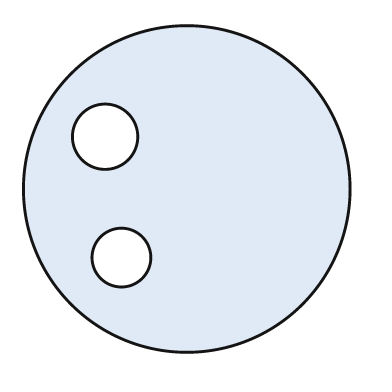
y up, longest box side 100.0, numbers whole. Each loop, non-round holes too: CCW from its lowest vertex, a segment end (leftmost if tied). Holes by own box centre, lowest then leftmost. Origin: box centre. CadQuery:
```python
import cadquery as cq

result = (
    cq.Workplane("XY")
    .moveTo(0.0, 0.0)
    .circle(50.0)
    .moveTo(-20.0, -21.0)
    .circle(9.0)
    .moveTo(-25.0, 16.0)
    .circle(10.0)
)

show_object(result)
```